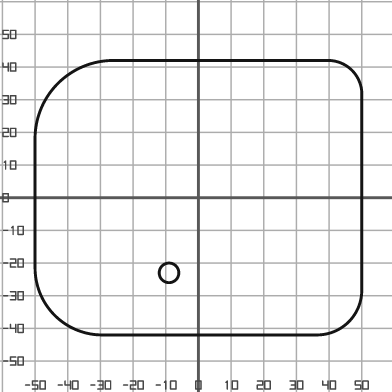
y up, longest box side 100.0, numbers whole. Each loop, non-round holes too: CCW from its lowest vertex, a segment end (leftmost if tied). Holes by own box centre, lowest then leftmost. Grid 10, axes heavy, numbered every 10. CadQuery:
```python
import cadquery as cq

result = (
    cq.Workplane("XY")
    .moveTo(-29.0, -42.0)
    .lineTo(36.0, -42.0)
    .threePointArc((46.0, -38.0), (50.0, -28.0))
    .lineTo(50.0, 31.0)
    .threePointArc((47.0, 39.0), (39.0, 42.0))
    .lineTo(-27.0, 42.0)
    .threePointArc((-43.0, 35.0), (-50.0, 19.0))
    .lineTo(-50.0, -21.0)
    .threePointArc((-44.0, -36.0), (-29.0, -42.0))
    .close()
    .moveTo(-9.0, -23.0)
    .circle(3.0)
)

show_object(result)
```